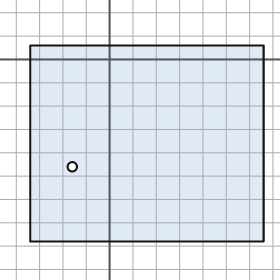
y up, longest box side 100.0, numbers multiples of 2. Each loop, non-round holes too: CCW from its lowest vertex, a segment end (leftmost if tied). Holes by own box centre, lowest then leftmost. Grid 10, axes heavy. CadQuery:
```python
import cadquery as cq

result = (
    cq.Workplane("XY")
    .moveTo(-34.0, -78.0)
    .lineTo(66.0, -78.0)
    .lineTo(66.0, 6.0)
    .lineTo(-34.0, 6.0)
    .close()
    .moveTo(-16.0, -46.0)
    .circle(2.0)
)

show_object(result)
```